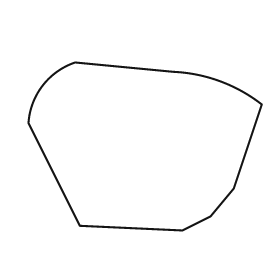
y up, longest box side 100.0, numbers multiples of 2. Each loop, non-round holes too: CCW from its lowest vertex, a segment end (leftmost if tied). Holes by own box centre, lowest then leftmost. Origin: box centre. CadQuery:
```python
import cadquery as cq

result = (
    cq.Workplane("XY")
    .moveTo(16.0, -36.0)
    .lineTo(28.0, -30.0)
    .lineTo(38.0, -18.0)
    .lineTo(50.0, 18.0)
    .threePointArc((32.0, 28.0), (12.0, 32.0))
    .lineTo(-30.0, 36.0)
    .threePointArc((-44.0, 26.0), (-50.0, 10.0))
    .lineTo(-28.0, -34.0)
    .close()
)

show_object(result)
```